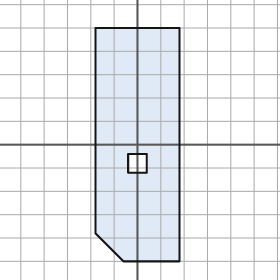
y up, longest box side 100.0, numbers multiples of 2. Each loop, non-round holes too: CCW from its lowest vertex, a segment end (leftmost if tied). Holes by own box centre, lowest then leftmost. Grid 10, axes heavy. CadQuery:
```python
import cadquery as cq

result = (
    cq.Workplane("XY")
    .moveTo(-6.0, -50.0)
    .lineTo(18.0, -50.0)
    .lineTo(18.0, 50.0)
    .lineTo(-18.0, 50.0)
    .lineTo(-18.0, -38.0)
    .close()
    .moveTo(-4.0, -12.0)
    .lineTo(4.0, -12.0)
    .lineTo(4.0, -4.0)
    .lineTo(-4.0, -4.0)
    .close()
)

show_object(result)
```